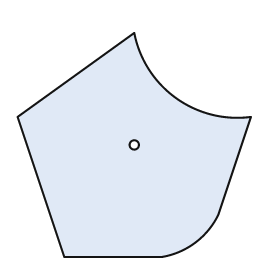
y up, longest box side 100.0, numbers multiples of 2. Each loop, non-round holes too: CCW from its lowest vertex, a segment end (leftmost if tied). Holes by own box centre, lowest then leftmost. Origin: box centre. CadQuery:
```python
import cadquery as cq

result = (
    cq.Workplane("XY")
    .moveTo(-30.0, -48.0)
    .lineTo(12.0, -48.0)
    .threePointArc((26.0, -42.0), (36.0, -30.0))
    .lineTo(50.0, 12.0)
    .threePointArc((18.0, 20.0), (0.0, 48.0))
    .lineTo(-50.0, 12.0)
    .close()
    .moveTo(0.0, 0.0)
    .circle(2.0)
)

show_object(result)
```